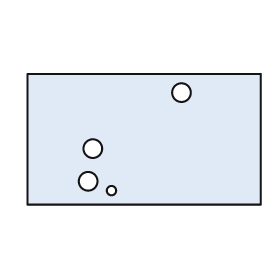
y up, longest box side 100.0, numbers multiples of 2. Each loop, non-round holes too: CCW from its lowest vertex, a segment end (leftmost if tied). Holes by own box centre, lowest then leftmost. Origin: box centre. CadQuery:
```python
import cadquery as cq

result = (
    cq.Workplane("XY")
    .moveTo(-50.0, -28.0)
    .lineTo(50.0, -28.0)
    .lineTo(50.0, 28.0)
    .lineTo(-50.0, 28.0)
    .close()
    .moveTo(-14.0, -22.0)
    .circle(2.0)
    .moveTo(-24.0, -18.0)
    .circle(4.0)
    .moveTo(-22.0, -4.0)
    .circle(4.0)
    .moveTo(16.0, 20.0)
    .circle(4.0)
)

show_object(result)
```